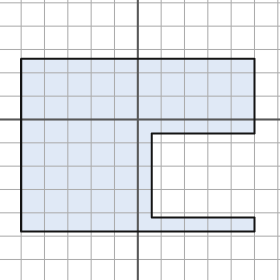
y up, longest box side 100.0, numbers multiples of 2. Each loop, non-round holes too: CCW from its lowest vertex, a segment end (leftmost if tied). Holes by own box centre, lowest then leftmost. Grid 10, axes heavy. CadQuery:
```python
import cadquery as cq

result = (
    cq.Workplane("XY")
    .moveTo(-50.0, -48.0)
    .lineTo(50.0, -48.0)
    .lineTo(50.0, -42.0)
    .lineTo(6.0, -42.0)
    .lineTo(6.0, -6.0)
    .lineTo(50.0, -6.0)
    .lineTo(50.0, 26.0)
    .lineTo(-50.0, 26.0)
    .close()
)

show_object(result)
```